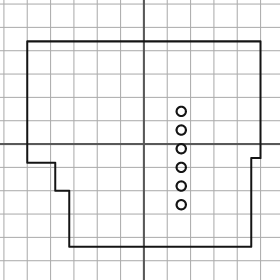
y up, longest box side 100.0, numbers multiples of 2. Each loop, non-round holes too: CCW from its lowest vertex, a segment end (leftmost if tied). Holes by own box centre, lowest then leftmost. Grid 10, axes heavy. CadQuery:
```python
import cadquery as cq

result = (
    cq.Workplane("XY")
    .moveTo(-32.0, -44.0)
    .lineTo(46.0, -44.0)
    .lineTo(46.0, -6.0)
    .lineTo(50.0, -6.0)
    .lineTo(50.0, 44.0)
    .lineTo(-50.0, 44.0)
    .lineTo(-50.0, -8.0)
    .lineTo(-38.0, -8.0)
    .lineTo(-38.0, -20.0)
    .lineTo(-32.0, -20.0)
    .close()
    .moveTo(16.0, -26.0)
    .circle(2.0)
    .moveTo(16.0, -18.0)
    .circle(2.0)
    .moveTo(16.0, -10.0)
    .circle(2.0)
    .moveTo(16.0, -2.0)
    .circle(2.0)
    .moveTo(16.0, 6.0)
    .circle(2.0)
    .moveTo(16.0, 14.0)
    .circle(2.0)
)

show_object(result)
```